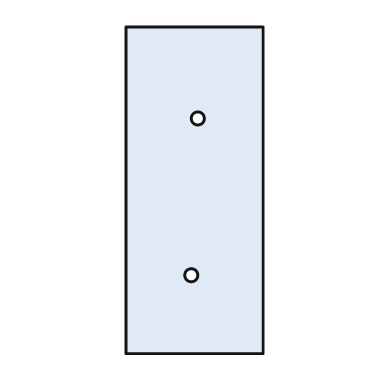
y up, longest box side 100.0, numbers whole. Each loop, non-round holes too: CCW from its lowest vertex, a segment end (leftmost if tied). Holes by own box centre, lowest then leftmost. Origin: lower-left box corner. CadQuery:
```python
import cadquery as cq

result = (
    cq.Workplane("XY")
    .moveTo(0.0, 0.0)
    .lineTo(42.0, 0.0)
    .lineTo(42.0, 100.0)
    .lineTo(0.0, 100.0)
    .close()
    .moveTo(20.0, 24.0)
    .circle(2.0)
    .moveTo(22.0, 72.0)
    .circle(2.0)
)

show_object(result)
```